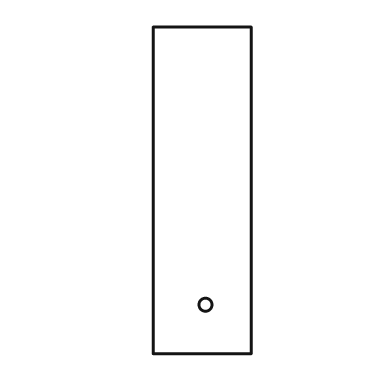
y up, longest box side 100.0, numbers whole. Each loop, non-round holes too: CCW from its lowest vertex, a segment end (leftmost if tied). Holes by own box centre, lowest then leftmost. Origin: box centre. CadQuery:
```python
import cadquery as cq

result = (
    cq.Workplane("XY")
    .moveTo(-15.0, -50.0)
    .lineTo(15.0, -50.0)
    .lineTo(15.0, 50.0)
    .lineTo(-15.0, 50.0)
    .close()
    .moveTo(1.0, -35.0)
    .circle(2.0)
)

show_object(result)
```